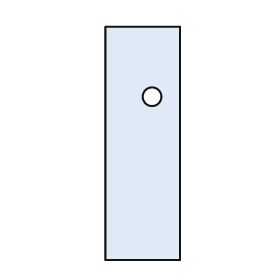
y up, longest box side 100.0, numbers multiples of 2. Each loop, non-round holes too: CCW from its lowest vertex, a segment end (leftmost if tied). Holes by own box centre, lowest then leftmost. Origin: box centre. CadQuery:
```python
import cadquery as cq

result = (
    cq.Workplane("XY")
    .moveTo(-16.0, -50.0)
    .lineTo(16.0, -50.0)
    .lineTo(16.0, 50.0)
    .lineTo(-16.0, 50.0)
    .close()
    .moveTo(4.0, 20.0)
    .circle(4.0)
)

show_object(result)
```